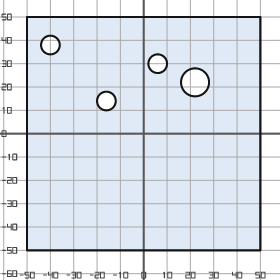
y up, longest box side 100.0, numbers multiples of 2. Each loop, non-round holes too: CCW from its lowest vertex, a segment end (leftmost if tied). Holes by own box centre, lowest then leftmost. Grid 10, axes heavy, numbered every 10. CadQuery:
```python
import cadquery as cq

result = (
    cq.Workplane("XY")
    .moveTo(-50.0, -50.0)
    .lineTo(50.0, -50.0)
    .lineTo(50.0, 50.0)
    .lineTo(-50.0, 50.0)
    .close()
    .moveTo(-16.0, 14.0)
    .circle(4.0)
    .moveTo(22.0, 22.0)
    .circle(6.0)
    .moveTo(6.0, 30.0)
    .circle(4.0)
    .moveTo(-40.0, 38.0)
    .circle(4.0)
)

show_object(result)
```